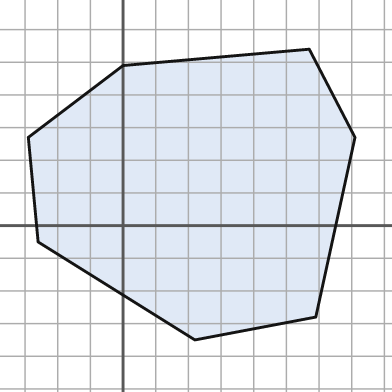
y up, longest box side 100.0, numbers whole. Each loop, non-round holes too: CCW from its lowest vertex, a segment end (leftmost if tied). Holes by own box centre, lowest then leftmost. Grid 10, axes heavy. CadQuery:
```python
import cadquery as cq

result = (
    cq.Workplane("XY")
    .moveTo(22.0, -35.0)
    .lineTo(59.0, -28.0)
    .lineTo(71.0, 27.0)
    .lineTo(57.0, 54.0)
    .lineTo(0.0, 49.0)
    .lineTo(-29.0, 27.0)
    .lineTo(-26.0, -5.0)
    .close()
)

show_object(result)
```